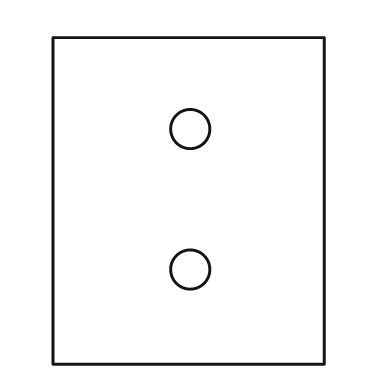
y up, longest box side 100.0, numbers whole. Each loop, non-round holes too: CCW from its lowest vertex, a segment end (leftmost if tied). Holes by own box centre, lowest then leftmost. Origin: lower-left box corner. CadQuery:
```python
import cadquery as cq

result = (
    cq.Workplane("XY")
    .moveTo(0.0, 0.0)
    .lineTo(83.0, 0.0)
    .lineTo(83.0, 100.0)
    .lineTo(0.0, 100.0)
    .close()
    .moveTo(42.0, 29.0)
    .circle(6.0)
    .moveTo(42.0, 72.0)
    .circle(6.0)
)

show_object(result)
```